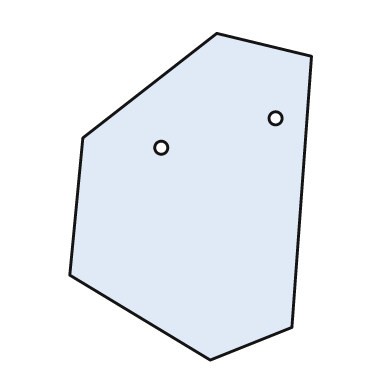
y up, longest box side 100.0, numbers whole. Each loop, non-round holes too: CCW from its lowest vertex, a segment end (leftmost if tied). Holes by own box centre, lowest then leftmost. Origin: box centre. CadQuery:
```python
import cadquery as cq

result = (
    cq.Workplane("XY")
    .moveTo(6.0, -50.0)
    .lineTo(31.0, -40.0)
    .lineTo(37.0, 43.0)
    .lineTo(8.0, 50.0)
    .lineTo(-33.0, 18.0)
    .lineTo(-37.0, -24.0)
    .close()
    .moveTo(-9.0, 15.0)
    .circle(2.0)
    .moveTo(26.0, 24.0)
    .circle(2.0)
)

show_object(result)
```